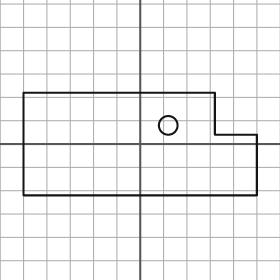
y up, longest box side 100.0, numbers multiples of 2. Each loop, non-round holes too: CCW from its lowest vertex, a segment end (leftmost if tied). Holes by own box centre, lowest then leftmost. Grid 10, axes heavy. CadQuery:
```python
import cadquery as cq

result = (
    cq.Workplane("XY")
    .moveTo(-50.0, -22.0)
    .lineTo(50.0, -22.0)
    .lineTo(50.0, 4.0)
    .lineTo(32.0, 4.0)
    .lineTo(32.0, 22.0)
    .lineTo(-50.0, 22.0)
    .close()
    .moveTo(12.0, 8.0)
    .circle(4.0)
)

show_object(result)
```